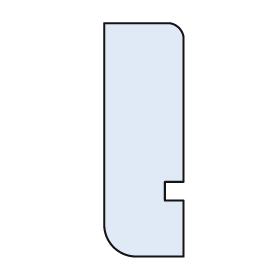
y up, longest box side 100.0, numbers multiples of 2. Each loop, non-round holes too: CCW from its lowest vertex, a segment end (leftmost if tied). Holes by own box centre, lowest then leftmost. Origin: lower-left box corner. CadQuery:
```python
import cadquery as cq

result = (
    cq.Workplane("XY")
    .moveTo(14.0, 0.0)
    .lineTo(34.0, 0.0)
    .lineTo(34.0, 24.0)
    .lineTo(26.0, 24.0)
    .lineTo(26.0, 32.0)
    .lineTo(34.0, 32.0)
    .lineTo(34.0, 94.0)
    .threePointArc((32.0, 98.0), (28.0, 100.0))
    .lineTo(0.0, 100.0)
    .lineTo(0.0, 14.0)
    .threePointArc((4.0, 4.0), (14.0, 0.0))
    .close()
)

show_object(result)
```